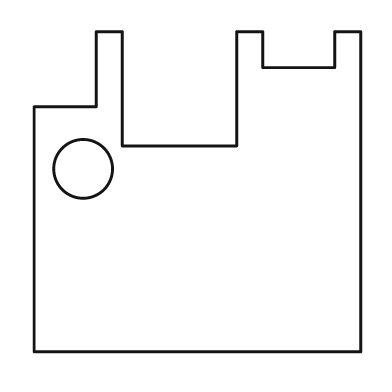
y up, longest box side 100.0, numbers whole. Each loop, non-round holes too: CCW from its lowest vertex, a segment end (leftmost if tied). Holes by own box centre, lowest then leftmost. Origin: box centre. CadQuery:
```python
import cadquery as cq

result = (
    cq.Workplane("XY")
    .moveTo(-50.0, -49.0)
    .lineTo(50.0, -49.0)
    .lineTo(50.0, 49.0)
    .lineTo(42.0, 49.0)
    .lineTo(42.0, 38.0)
    .lineTo(20.0, 38.0)
    .lineTo(20.0, 49.0)
    .lineTo(12.0, 49.0)
    .lineTo(12.0, 14.0)
    .lineTo(-23.0, 14.0)
    .lineTo(-23.0, 49.0)
    .lineTo(-31.0, 49.0)
    .lineTo(-31.0, 26.0)
    .lineTo(-50.0, 26.0)
    .close()
    .moveTo(-35.0, 7.0)
    .circle(9.0)
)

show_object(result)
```